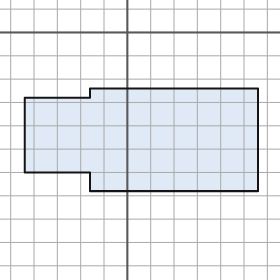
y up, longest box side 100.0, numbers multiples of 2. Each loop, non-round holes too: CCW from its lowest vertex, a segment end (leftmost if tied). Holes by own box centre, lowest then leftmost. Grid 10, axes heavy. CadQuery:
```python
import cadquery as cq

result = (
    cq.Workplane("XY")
    .moveTo(-16.0, -68.0)
    .lineTo(56.0, -68.0)
    .lineTo(56.0, -24.0)
    .lineTo(-16.0, -24.0)
    .lineTo(-16.0, -28.0)
    .lineTo(-44.0, -28.0)
    .lineTo(-44.0, -60.0)
    .lineTo(-16.0, -60.0)
    .close()
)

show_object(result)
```